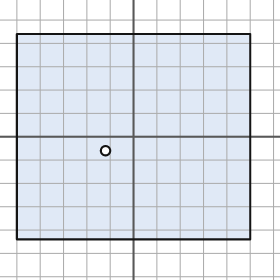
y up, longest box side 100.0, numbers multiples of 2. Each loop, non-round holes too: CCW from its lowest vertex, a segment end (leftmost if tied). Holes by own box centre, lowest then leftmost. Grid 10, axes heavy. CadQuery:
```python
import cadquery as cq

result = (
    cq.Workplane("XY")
    .moveTo(-50.0, -44.0)
    .lineTo(50.0, -44.0)
    .lineTo(50.0, 44.0)
    .lineTo(-50.0, 44.0)
    .close()
    .moveTo(-12.0, -6.0)
    .circle(2.0)
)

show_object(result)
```